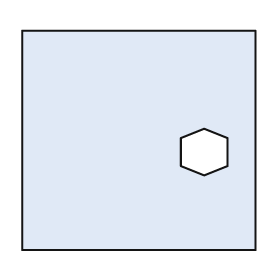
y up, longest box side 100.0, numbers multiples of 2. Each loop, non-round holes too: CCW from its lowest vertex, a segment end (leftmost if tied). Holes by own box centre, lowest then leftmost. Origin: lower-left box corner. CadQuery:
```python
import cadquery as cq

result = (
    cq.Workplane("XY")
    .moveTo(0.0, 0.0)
    .lineTo(100.0, 0.0)
    .lineTo(100.0, 94.0)
    .lineTo(0.0, 94.0)
    .close()
    .moveTo(78.0, 32.0)
    .lineTo(88.0, 36.0)
    .lineTo(88.0, 48.0)
    .lineTo(78.0, 52.0)
    .lineTo(68.0, 48.0)
    .lineTo(68.0, 36.0)
    .close()
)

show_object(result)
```